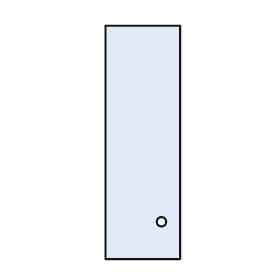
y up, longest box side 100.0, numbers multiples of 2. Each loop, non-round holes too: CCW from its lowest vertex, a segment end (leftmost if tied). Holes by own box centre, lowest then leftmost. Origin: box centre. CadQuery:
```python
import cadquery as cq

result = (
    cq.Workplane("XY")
    .moveTo(-16.0, -50.0)
    .lineTo(16.0, -50.0)
    .lineTo(16.0, 50.0)
    .lineTo(-16.0, 50.0)
    .close()
    .moveTo(8.0, -34.0)
    .circle(2.0)
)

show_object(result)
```